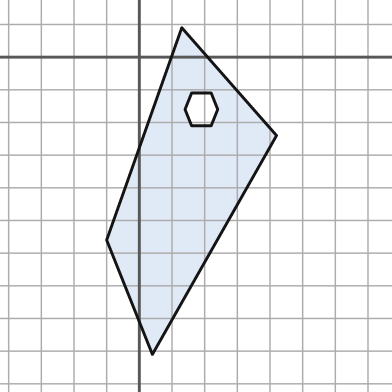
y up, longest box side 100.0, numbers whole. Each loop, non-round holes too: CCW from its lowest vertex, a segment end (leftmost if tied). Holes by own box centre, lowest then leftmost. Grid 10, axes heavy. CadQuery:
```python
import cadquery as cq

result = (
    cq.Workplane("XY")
    .moveTo(4.0, -91.0)
    .lineTo(42.0, -24.0)
    .lineTo(13.0, 9.0)
    .lineTo(-10.0, -56.0)
    .close()
    .moveTo(16.0, -21.0)
    .lineTo(22.0, -21.0)
    .lineTo(24.0, -16.0)
    .lineTo(22.0, -11.0)
    .lineTo(16.0, -11.0)
    .lineTo(14.0, -16.0)
    .close()
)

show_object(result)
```